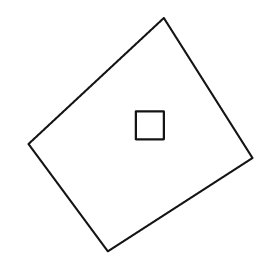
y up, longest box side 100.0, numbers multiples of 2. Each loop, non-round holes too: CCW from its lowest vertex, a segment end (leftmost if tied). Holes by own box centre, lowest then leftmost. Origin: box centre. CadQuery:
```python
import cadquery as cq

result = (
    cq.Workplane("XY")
    .moveTo(-14.0, -50.0)
    .lineTo(48.0, -10.0)
    .lineTo(10.0, 50.0)
    .lineTo(-48.0, -4.0)
    .close()
    .moveTo(-2.0, -2.0)
    .lineTo(10.0, -2.0)
    .lineTo(10.0, 10.0)
    .lineTo(-2.0, 10.0)
    .close()
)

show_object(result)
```